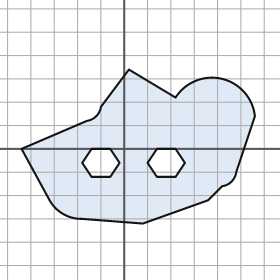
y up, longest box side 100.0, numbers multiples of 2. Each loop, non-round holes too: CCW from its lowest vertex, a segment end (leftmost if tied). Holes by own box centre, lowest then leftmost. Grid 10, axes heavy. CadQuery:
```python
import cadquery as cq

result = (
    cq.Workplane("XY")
    .moveTo(8.0, -32.0)
    .lineTo(36.0, -22.0)
    .lineTo(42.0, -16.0)
    .threePointArc((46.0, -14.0), (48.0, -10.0))
    .lineTo(56.0, 14.0)
    .threePointArc((42.0, 30.0), (22.0, 22.0))
    .lineTo(2.0, 34.0)
    .lineTo(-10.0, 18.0)
    .threePointArc((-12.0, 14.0), (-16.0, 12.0))
    .lineTo(-44.0, 0.0)
    .lineTo(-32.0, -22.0)
    .threePointArc((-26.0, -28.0), (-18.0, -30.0))
    .close()
    .moveTo(-14.0, -12.0)
    .lineTo(-6.0, -12.0)
    .lineTo(-2.0, -6.0)
    .lineTo(-6.0, 0.0)
    .lineTo(-14.0, 0.0)
    .lineTo(-18.0, -6.0)
    .close()
    .moveTo(14.0, -12.0)
    .lineTo(22.0, -12.0)
    .lineTo(26.0, -6.0)
    .lineTo(22.0, 0.0)
    .lineTo(14.0, 0.0)
    .lineTo(10.0, -6.0)
    .close()
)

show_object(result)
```